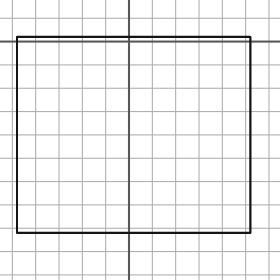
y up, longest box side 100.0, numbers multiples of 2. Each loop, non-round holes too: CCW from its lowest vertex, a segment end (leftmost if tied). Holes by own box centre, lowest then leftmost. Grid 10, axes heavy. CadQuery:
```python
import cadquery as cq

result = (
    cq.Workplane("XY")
    .moveTo(-48.0, -82.0)
    .lineTo(52.0, -82.0)
    .lineTo(52.0, 2.0)
    .lineTo(-48.0, 2.0)
    .close()
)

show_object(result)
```